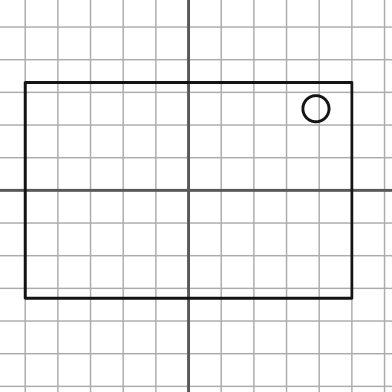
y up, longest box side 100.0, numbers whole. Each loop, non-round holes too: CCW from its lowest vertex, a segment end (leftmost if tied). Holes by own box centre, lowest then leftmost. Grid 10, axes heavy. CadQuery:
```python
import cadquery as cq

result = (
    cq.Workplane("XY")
    .moveTo(-50.0, -33.0)
    .lineTo(50.0, -33.0)
    .lineTo(50.0, 33.0)
    .lineTo(-50.0, 33.0)
    .close()
    .moveTo(39.0, 25.0)
    .circle(4.0)
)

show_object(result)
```